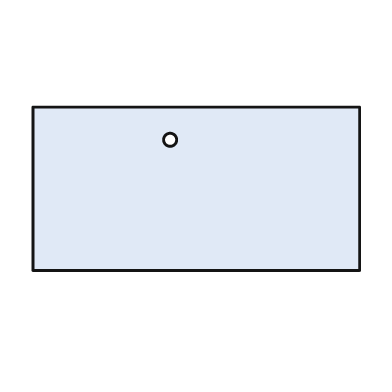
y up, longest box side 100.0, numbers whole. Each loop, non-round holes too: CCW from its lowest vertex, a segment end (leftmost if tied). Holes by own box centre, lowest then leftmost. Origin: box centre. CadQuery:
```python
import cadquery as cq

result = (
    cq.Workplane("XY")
    .moveTo(-50.0, -25.0)
    .lineTo(50.0, -25.0)
    .lineTo(50.0, 25.0)
    .lineTo(-50.0, 25.0)
    .close()
    .moveTo(-8.0, 15.0)
    .circle(2.0)
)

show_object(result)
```